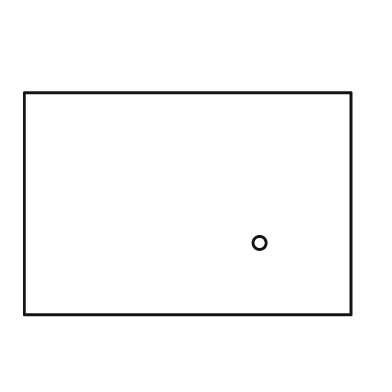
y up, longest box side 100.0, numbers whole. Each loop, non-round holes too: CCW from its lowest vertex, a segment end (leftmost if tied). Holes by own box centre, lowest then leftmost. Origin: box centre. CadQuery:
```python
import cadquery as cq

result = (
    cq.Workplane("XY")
    .moveTo(-50.0, -34.0)
    .lineTo(50.0, -34.0)
    .lineTo(50.0, 34.0)
    .lineTo(-50.0, 34.0)
    .close()
    .moveTo(22.0, -12.0)
    .circle(2.0)
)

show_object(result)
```